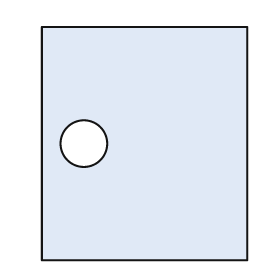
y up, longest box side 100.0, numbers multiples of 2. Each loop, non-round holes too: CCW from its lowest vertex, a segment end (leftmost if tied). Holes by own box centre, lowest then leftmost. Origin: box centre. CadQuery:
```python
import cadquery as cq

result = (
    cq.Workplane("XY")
    .moveTo(-44.0, -50.0)
    .lineTo(44.0, -50.0)
    .lineTo(44.0, 50.0)
    .lineTo(-44.0, 50.0)
    .close()
    .moveTo(-26.0, 0.0)
    .circle(10.0)
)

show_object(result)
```